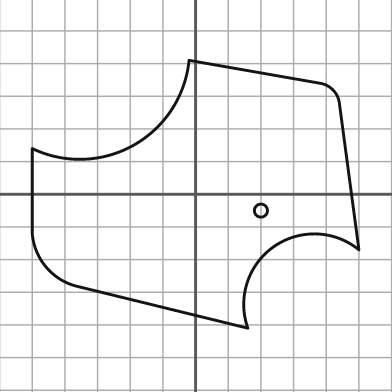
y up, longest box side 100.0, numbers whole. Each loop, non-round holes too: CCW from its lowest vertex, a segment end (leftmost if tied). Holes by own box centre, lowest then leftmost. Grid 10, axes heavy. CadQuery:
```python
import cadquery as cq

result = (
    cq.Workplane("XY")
    .moveTo(16.0, -41.0)
    .threePointArc((24.0, -16.0), (50.0, -17.0))
    .lineTo(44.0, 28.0)
    .threePointArc((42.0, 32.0), (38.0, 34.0))
    .lineTo(-2.0, 41.0)
    .threePointArc((-19.0, 15.0), (-50.0, 14.0))
    .lineTo(-50.0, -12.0)
    .threePointArc((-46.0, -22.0), (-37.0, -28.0))
    .close()
    .moveTo(20.0, -5.0)
    .circle(2.0)
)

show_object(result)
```